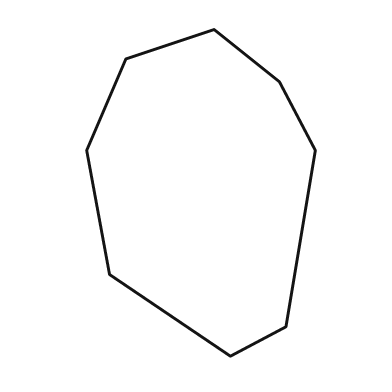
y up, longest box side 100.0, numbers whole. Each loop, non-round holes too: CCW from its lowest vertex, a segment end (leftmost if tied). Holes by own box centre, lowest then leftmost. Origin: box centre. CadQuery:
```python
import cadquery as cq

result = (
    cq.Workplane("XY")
    .moveTo(9.0, -50.0)
    .lineTo(26.0, -41.0)
    .lineTo(35.0, 13.0)
    .lineTo(24.0, 34.0)
    .lineTo(4.0, 50.0)
    .lineTo(-23.0, 41.0)
    .lineTo(-35.0, 13.0)
    .lineTo(-28.0, -25.0)
    .close()
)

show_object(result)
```